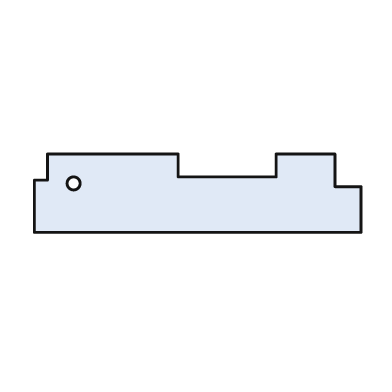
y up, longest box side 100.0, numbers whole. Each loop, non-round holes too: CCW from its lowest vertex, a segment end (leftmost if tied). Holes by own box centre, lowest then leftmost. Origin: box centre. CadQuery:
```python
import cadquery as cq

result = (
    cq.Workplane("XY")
    .moveTo(-50.0, -12.0)
    .lineTo(50.0, -12.0)
    .lineTo(50.0, 2.0)
    .lineTo(42.0, 2.0)
    .lineTo(42.0, 12.0)
    .lineTo(24.0, 12.0)
    .lineTo(24.0, 5.0)
    .lineTo(-6.0, 5.0)
    .lineTo(-6.0, 12.0)
    .lineTo(-46.0, 12.0)
    .lineTo(-46.0, 4.0)
    .lineTo(-50.0, 4.0)
    .close()
    .moveTo(-38.0, 3.0)
    .circle(2.0)
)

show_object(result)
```